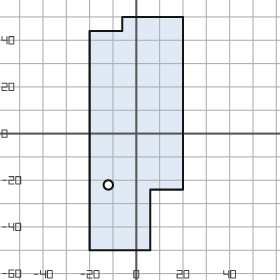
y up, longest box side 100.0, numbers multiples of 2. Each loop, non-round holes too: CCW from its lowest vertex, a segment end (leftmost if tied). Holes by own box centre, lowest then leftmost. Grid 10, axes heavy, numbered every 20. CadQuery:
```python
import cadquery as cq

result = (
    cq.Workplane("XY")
    .moveTo(-20.0, -50.0)
    .lineTo(6.0, -50.0)
    .lineTo(6.0, -24.0)
    .lineTo(20.0, -24.0)
    .lineTo(20.0, 50.0)
    .lineTo(-6.0, 50.0)
    .lineTo(-6.0, 44.0)
    .lineTo(-20.0, 44.0)
    .close()
    .moveTo(-12.0, -22.0)
    .circle(2.0)
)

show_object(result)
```